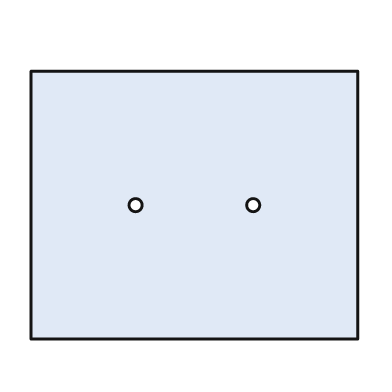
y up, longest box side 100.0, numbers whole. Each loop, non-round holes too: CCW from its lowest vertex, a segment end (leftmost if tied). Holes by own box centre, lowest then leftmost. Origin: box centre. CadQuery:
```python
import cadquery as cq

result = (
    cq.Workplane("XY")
    .moveTo(-50.0, -41.0)
    .lineTo(50.0, -41.0)
    .lineTo(50.0, 41.0)
    .lineTo(-50.0, 41.0)
    .close()
    .moveTo(-18.0, 0.0)
    .circle(2.0)
    .moveTo(18.0, 0.0)
    .circle(2.0)
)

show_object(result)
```